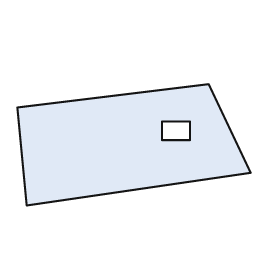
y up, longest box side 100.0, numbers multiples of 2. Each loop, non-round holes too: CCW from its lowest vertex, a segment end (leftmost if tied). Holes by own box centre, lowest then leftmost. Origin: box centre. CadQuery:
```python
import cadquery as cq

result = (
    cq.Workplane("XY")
    .moveTo(-46.0, -26.0)
    .lineTo(50.0, -12.0)
    .lineTo(32.0, 26.0)
    .lineTo(-50.0, 16.0)
    .close()
    .moveTo(12.0, 2.0)
    .lineTo(24.0, 2.0)
    .lineTo(24.0, 10.0)
    .lineTo(12.0, 10.0)
    .close()
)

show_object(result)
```